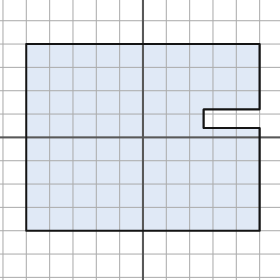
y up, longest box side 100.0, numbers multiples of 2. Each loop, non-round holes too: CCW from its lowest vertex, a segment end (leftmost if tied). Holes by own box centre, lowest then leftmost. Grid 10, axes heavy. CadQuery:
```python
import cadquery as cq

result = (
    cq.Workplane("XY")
    .moveTo(-50.0, -40.0)
    .lineTo(50.0, -40.0)
    .lineTo(50.0, 4.0)
    .lineTo(26.0, 4.0)
    .lineTo(26.0, 12.0)
    .lineTo(50.0, 12.0)
    .lineTo(50.0, 40.0)
    .lineTo(-50.0, 40.0)
    .close()
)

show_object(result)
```